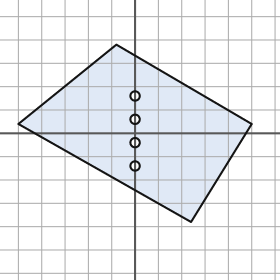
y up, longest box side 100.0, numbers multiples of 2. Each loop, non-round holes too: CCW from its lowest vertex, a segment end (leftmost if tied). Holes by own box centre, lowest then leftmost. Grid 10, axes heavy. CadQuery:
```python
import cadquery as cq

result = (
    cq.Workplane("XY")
    .moveTo(24.0, -38.0)
    .lineTo(50.0, 4.0)
    .lineTo(-8.0, 38.0)
    .lineTo(-50.0, 4.0)
    .close()
    .moveTo(0.0, -14.0)
    .circle(2.0)
    .moveTo(0.0, -4.0)
    .circle(2.0)
    .moveTo(0.0, 6.0)
    .circle(2.0)
    .moveTo(0.0, 16.0)
    .circle(2.0)
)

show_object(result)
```